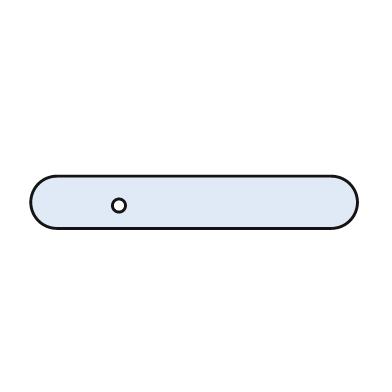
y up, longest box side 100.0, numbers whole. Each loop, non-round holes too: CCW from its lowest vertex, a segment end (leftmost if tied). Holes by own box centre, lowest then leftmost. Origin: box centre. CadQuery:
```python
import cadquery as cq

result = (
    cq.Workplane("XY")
    .moveTo(-42.0, -8.0)
    .lineTo(42.0, -8.0)
    .threePointArc((50.0, 0.0), (42.0, 8.0))
    .lineTo(-42.0, 8.0)
    .threePointArc((-50.0, 0.0), (-42.0, -8.0))
    .close()
    .moveTo(-23.0, -1.0)
    .circle(2.0)
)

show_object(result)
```